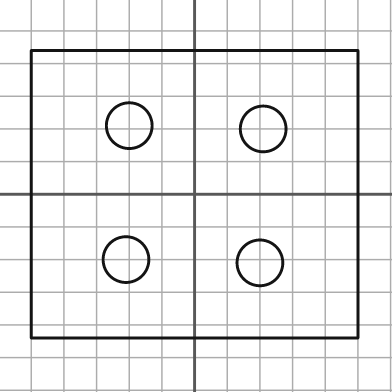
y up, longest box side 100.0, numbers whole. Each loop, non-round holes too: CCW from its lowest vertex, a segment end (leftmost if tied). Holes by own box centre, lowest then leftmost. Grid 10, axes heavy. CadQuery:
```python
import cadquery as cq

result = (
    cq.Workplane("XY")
    .moveTo(-50.0, -44.0)
    .lineTo(50.0, -44.0)
    .lineTo(50.0, 44.0)
    .lineTo(-50.0, 44.0)
    .close()
    .moveTo(20.0, -21.0)
    .circle(7.0)
    .moveTo(-21.0, -20.0)
    .circle(7.0)
    .moveTo(21.0, 20.0)
    .circle(7.0)
    .moveTo(-20.0, 21.0)
    .circle(7.0)
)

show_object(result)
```